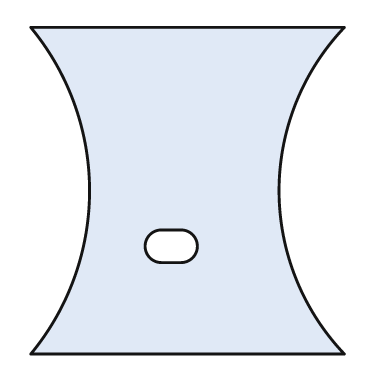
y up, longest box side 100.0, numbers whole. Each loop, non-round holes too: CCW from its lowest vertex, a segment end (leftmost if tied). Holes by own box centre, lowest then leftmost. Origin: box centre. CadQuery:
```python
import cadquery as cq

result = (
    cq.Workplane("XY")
    .moveTo(-48.0, -50.0)
    .lineTo(48.0, -50.0)
    .threePointArc((28.0, 0.0), (48.0, 50.0))
    .lineTo(-48.0, 50.0)
    .threePointArc((-30.0, 0.0), (-48.0, -50.0))
    .close()
    .moveTo(-8.0, -22.0)
    .lineTo(-2.0, -22.0)
    .threePointArc((3.0, -17.0), (-2.0, -12.0))
    .lineTo(-8.0, -12.0)
    .threePointArc((-13.0, -17.0), (-8.0, -22.0))
    .close()
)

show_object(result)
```